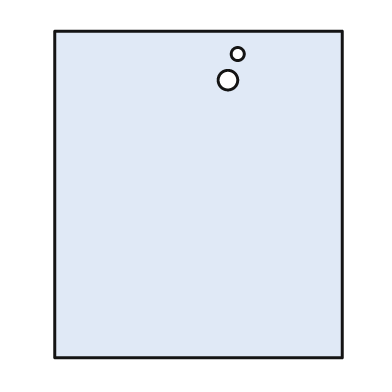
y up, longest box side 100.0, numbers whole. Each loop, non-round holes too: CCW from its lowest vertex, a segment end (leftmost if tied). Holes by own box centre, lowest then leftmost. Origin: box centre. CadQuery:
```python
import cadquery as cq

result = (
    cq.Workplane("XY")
    .moveTo(-44.0, -50.0)
    .lineTo(44.0, -50.0)
    .lineTo(44.0, 50.0)
    .lineTo(-44.0, 50.0)
    .close()
    .moveTo(9.0, 35.0)
    .circle(3.0)
    .moveTo(12.0, 43.0)
    .circle(2.0)
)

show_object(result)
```